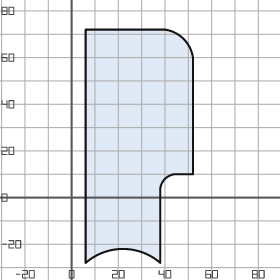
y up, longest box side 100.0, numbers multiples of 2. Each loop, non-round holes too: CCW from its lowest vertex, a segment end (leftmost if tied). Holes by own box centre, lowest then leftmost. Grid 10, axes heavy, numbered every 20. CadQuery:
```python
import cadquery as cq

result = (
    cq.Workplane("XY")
    .moveTo(6.0, -28.0)
    .threePointArc((22.0, -22.0), (38.0, -28.0))
    .lineTo(38.0, 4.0)
    .threePointArc((40.0, 8.0), (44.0, 10.0))
    .lineTo(52.0, 10.0)
    .lineTo(52.0, 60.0)
    .threePointArc((48.0, 68.0), (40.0, 72.0))
    .lineTo(6.0, 72.0)
    .close()
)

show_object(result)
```